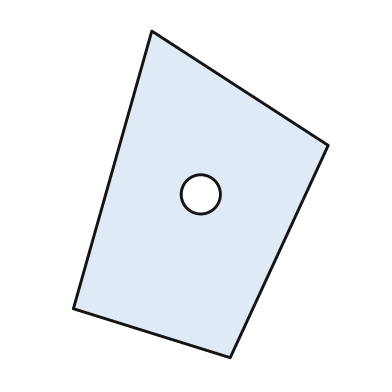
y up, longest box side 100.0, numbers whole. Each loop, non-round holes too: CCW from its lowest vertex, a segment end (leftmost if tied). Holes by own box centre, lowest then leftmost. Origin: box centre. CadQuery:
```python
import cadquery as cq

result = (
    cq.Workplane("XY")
    .moveTo(9.0, -50.0)
    .lineTo(39.0, 15.0)
    .lineTo(-15.0, 50.0)
    .lineTo(-39.0, -35.0)
    .close()
    .moveTo(0.0, 0.0)
    .circle(6.0)
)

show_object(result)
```